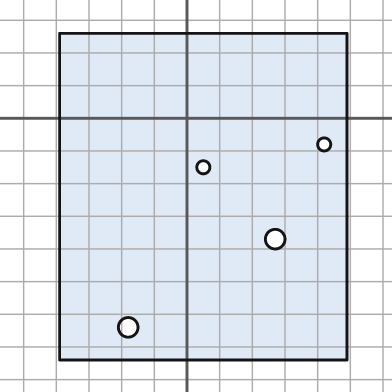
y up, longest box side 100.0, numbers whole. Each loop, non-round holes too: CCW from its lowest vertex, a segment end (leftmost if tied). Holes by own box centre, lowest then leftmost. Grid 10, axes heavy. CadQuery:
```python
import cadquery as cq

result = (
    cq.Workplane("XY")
    .moveTo(-39.0, -74.0)
    .lineTo(49.0, -74.0)
    .lineTo(49.0, 26.0)
    .lineTo(-39.0, 26.0)
    .close()
    .moveTo(-18.0, -64.0)
    .circle(3.0)
    .moveTo(27.0, -37.0)
    .circle(3.0)
    .moveTo(5.0, -15.0)
    .circle(2.0)
    .moveTo(42.0, -8.0)
    .circle(2.0)
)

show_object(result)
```